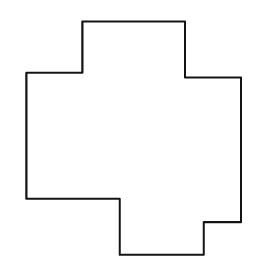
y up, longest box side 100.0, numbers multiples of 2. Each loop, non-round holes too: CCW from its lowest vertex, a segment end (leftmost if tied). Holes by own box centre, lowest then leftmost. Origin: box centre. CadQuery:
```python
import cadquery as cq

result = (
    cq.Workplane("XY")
    .moveTo(-6.0, -50.0)
    .lineTo(30.0, -50.0)
    .lineTo(30.0, -36.0)
    .lineTo(46.0, -36.0)
    .lineTo(46.0, 26.0)
    .lineTo(22.0, 26.0)
    .lineTo(22.0, 50.0)
    .lineTo(-22.0, 50.0)
    .lineTo(-22.0, 28.0)
    .lineTo(-46.0, 28.0)
    .lineTo(-46.0, -26.0)
    .lineTo(-6.0, -26.0)
    .close()
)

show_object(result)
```